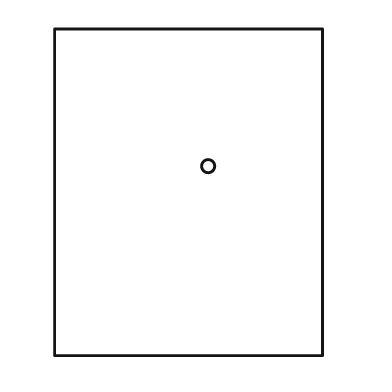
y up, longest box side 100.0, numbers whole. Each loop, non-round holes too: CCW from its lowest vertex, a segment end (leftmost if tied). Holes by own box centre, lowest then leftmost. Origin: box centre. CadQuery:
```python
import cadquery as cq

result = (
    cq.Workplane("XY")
    .moveTo(-41.0, -50.0)
    .lineTo(41.0, -50.0)
    .lineTo(41.0, 50.0)
    .lineTo(-41.0, 50.0)
    .close()
    .moveTo(6.0, 8.0)
    .circle(2.0)
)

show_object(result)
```